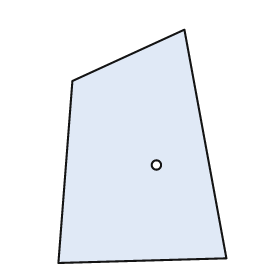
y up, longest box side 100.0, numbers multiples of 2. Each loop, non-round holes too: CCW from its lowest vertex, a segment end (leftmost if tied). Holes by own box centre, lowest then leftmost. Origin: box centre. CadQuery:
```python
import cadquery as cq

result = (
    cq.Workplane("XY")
    .moveTo(-36.0, -50.0)
    .lineTo(36.0, -48.0)
    .lineTo(18.0, 50.0)
    .lineTo(-30.0, 28.0)
    .close()
    .moveTo(6.0, -8.0)
    .circle(2.0)
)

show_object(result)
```